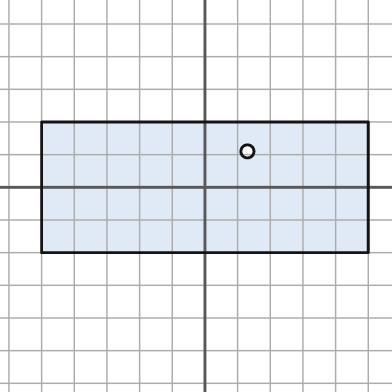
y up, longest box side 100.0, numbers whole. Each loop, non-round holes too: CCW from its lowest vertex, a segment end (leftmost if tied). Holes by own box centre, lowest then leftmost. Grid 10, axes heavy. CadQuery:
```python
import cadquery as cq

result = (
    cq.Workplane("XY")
    .moveTo(-50.0, -20.0)
    .lineTo(50.0, -20.0)
    .lineTo(50.0, 20.0)
    .lineTo(-50.0, 20.0)
    .close()
    .moveTo(13.0, 11.0)
    .circle(2.0)
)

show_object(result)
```